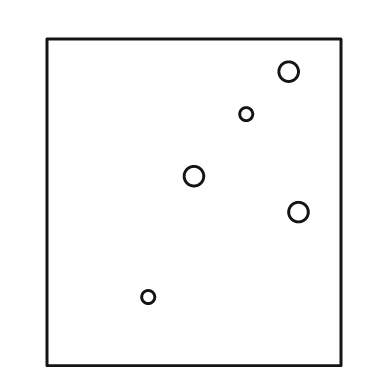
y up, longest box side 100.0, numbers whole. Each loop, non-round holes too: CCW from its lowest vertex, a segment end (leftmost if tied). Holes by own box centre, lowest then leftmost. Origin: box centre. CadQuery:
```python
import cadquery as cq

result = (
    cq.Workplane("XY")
    .moveTo(-45.0, -50.0)
    .lineTo(45.0, -50.0)
    .lineTo(45.0, 50.0)
    .lineTo(-45.0, 50.0)
    .close()
    .moveTo(-14.0, -29.0)
    .circle(2.0)
    .moveTo(32.0, -3.0)
    .circle(3.0)
    .moveTo(0.0, 8.0)
    .circle(3.0)
    .moveTo(16.0, 27.0)
    .circle(2.0)
    .moveTo(29.0, 40.0)
    .circle(3.0)
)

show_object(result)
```